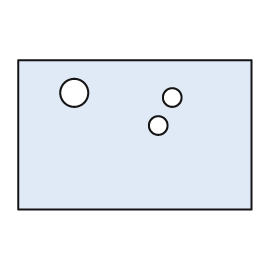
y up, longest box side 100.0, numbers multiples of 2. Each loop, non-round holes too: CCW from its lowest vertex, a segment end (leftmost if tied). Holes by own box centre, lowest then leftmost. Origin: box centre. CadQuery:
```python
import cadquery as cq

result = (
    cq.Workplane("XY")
    .moveTo(-50.0, -32.0)
    .lineTo(50.0, -32.0)
    .lineTo(50.0, 32.0)
    .lineTo(-50.0, 32.0)
    .close()
    .moveTo(10.0, 4.0)
    .circle(4.0)
    .moveTo(16.0, 16.0)
    .circle(4.0)
    .moveTo(-26.0, 18.0)
    .circle(6.0)
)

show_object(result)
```